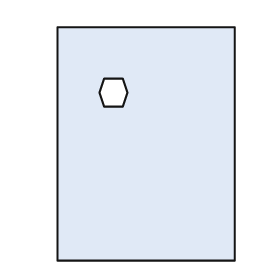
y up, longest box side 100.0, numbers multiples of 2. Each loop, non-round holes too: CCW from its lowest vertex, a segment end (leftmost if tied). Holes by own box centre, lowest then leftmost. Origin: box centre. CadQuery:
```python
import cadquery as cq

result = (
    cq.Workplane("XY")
    .moveTo(-38.0, -50.0)
    .lineTo(38.0, -50.0)
    .lineTo(38.0, 50.0)
    .lineTo(-38.0, 50.0)
    .close()
    .moveTo(-18.0, 16.0)
    .lineTo(-10.0, 16.0)
    .lineTo(-8.0, 22.0)
    .lineTo(-10.0, 28.0)
    .lineTo(-18.0, 28.0)
    .lineTo(-20.0, 22.0)
    .close()
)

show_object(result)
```